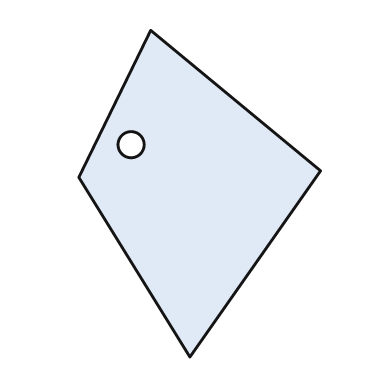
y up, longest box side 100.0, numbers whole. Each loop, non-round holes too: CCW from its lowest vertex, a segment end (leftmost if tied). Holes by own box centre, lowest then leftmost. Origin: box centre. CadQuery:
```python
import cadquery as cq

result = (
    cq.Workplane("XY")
    .moveTo(-3.0, -50.0)
    .lineTo(37.0, 7.0)
    .lineTo(-15.0, 50.0)
    .lineTo(-37.0, 5.0)
    .close()
    .moveTo(-21.0, 15.0)
    .circle(4.0)
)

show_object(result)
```